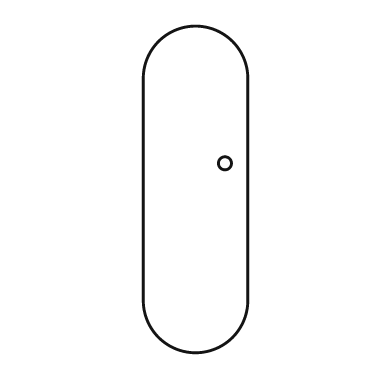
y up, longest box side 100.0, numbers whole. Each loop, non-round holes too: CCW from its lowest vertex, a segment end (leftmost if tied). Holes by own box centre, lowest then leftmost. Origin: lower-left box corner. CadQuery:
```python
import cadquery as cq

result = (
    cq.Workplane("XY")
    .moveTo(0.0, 16.0)
    .threePointArc((16.0, 0.0), (32.0, 16.0))
    .lineTo(32.0, 84.0)
    .threePointArc((16.0, 100.0), (0.0, 84.0))
    .close()
    .moveTo(25.0, 58.0)
    .circle(2.0)
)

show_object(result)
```